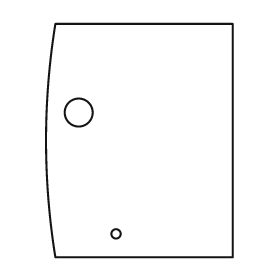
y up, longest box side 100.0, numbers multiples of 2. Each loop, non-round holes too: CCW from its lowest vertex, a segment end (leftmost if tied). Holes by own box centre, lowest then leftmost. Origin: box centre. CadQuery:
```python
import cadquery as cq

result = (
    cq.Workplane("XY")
    .moveTo(-36.0, -50.0)
    .lineTo(40.0, -50.0)
    .lineTo(40.0, 50.0)
    .lineTo(-36.0, 50.0)
    .threePointArc((-40.0, 0.0), (-36.0, -50.0))
    .close()
    .moveTo(-10.0, -40.0)
    .circle(2.0)
    .moveTo(-26.0, 12.0)
    .circle(6.0)
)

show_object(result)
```